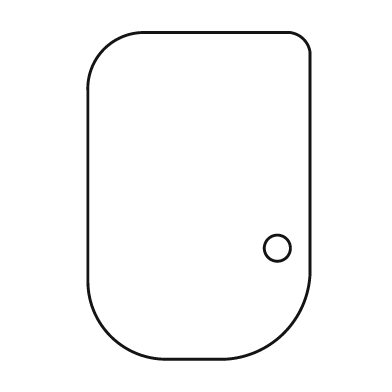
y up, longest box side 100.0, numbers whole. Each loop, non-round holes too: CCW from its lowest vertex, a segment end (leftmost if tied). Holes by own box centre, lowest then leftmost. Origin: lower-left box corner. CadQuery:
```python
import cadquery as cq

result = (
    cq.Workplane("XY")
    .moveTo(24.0, 0.0)
    .lineTo(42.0, 0.0)
    .threePointArc((60.0, 8.0), (68.0, 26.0))
    .lineTo(68.0, 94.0)
    .threePointArc((66.0, 98.0), (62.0, 100.0))
    .lineTo(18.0, 100.0)
    .threePointArc((5.0, 95.0), (0.0, 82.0))
    .lineTo(0.0, 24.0)
    .threePointArc((7.0, 7.0), (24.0, 0.0))
    .close()
    .moveTo(58.0, 34.0)
    .circle(4.0)
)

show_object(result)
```